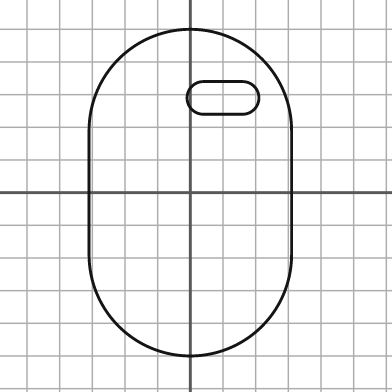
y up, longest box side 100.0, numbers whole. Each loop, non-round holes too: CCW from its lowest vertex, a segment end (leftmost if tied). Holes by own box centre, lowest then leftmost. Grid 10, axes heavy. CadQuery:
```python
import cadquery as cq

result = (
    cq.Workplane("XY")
    .moveTo(-31.0, -19.0)
    .threePointArc((0.0, -50.0), (31.0, -19.0))
    .lineTo(31.0, 19.0)
    .threePointArc((0.0, 50.0), (-31.0, 19.0))
    .close()
    .moveTo(4.0, 24.0)
    .lineTo(16.0, 24.0)
    .threePointArc((21.0, 29.0), (16.0, 34.0))
    .lineTo(4.0, 34.0)
    .threePointArc((-1.0, 29.0), (4.0, 24.0))
    .close()
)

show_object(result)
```